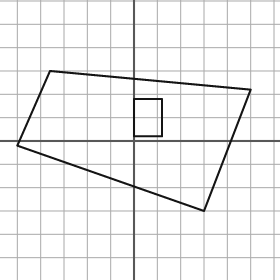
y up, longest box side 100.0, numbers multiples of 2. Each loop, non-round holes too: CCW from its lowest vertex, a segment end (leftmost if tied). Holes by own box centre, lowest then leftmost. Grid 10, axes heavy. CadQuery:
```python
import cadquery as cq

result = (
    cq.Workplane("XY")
    .moveTo(30.0, -30.0)
    .lineTo(50.0, 22.0)
    .lineTo(-36.0, 30.0)
    .lineTo(-50.0, -2.0)
    .close()
    .moveTo(0.0, 2.0)
    .lineTo(12.0, 2.0)
    .lineTo(12.0, 18.0)
    .lineTo(0.0, 18.0)
    .close()
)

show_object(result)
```